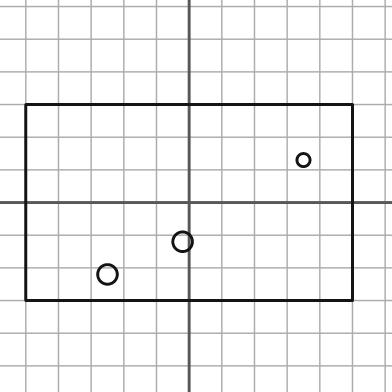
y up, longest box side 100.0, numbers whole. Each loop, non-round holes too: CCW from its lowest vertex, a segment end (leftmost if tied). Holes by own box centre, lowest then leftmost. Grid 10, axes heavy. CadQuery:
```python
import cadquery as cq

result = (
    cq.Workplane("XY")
    .moveTo(-50.0, -30.0)
    .lineTo(50.0, -30.0)
    .lineTo(50.0, 30.0)
    .lineTo(-50.0, 30.0)
    .close()
    .moveTo(-25.0, -22.0)
    .circle(3.0)
    .moveTo(-2.0, -12.0)
    .circle(3.0)
    .moveTo(35.0, 13.0)
    .circle(2.0)
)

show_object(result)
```